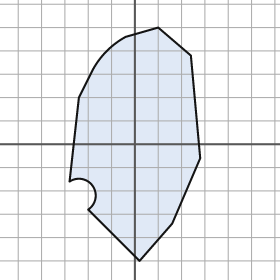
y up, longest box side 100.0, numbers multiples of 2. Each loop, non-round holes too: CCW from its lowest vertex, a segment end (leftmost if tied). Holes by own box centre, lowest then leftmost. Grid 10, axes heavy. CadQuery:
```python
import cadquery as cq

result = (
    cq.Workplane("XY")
    .moveTo(2.0, -50.0)
    .lineTo(16.0, -34.0)
    .lineTo(28.0, -6.0)
    .lineTo(24.0, 38.0)
    .lineTo(10.0, 50.0)
    .lineTo(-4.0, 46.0)
    .threePointArc((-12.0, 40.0), (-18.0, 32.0))
    .lineTo(-24.0, 20.0)
    .lineTo(-28.0, -16.0)
    .threePointArc((-18.0, -18.0), (-20.0, -28.0))
    .close()
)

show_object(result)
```